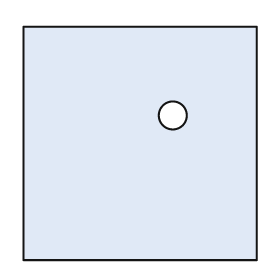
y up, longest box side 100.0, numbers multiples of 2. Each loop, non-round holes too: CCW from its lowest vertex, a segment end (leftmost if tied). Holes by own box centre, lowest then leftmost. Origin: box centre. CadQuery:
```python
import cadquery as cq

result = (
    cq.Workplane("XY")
    .moveTo(-50.0, -50.0)
    .lineTo(50.0, -50.0)
    .lineTo(50.0, 50.0)
    .lineTo(-50.0, 50.0)
    .close()
    .moveTo(14.0, 12.0)
    .circle(6.0)
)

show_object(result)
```